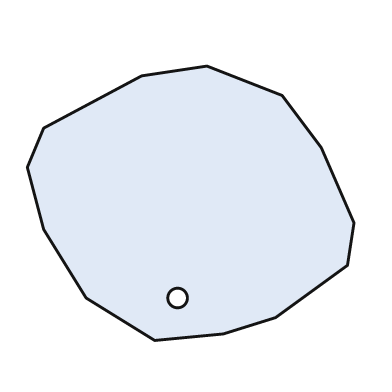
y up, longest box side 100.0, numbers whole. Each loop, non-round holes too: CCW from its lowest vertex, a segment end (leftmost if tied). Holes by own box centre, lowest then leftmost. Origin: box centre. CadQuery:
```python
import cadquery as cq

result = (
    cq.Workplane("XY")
    .moveTo(-11.0, -42.0)
    .lineTo(10.0, -40.0)
    .lineTo(26.0, -35.0)
    .lineTo(48.0, -19.0)
    .lineTo(50.0, -6.0)
    .lineTo(40.0, 17.0)
    .lineTo(28.0, 33.0)
    .lineTo(5.0, 42.0)
    .lineTo(-15.0, 39.0)
    .lineTo(-45.0, 23.0)
    .lineTo(-50.0, 11.0)
    .lineTo(-45.0, -8.0)
    .lineTo(-32.0, -29.0)
    .close()
    .moveTo(-4.0, -29.0)
    .circle(3.0)
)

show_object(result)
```